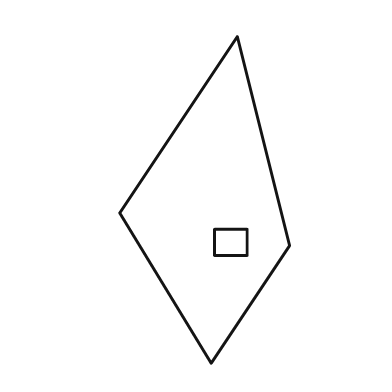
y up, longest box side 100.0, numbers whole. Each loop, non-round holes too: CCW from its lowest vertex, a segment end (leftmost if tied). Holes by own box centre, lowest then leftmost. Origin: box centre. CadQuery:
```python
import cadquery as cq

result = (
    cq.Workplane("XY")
    .moveTo(2.0, -50.0)
    .lineTo(26.0, -14.0)
    .lineTo(10.0, 50.0)
    .lineTo(-26.0, -4.0)
    .close()
    .moveTo(3.0, -17.0)
    .lineTo(13.0, -17.0)
    .lineTo(13.0, -9.0)
    .lineTo(3.0, -9.0)
    .close()
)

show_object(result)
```